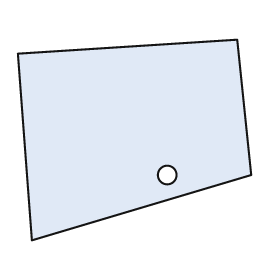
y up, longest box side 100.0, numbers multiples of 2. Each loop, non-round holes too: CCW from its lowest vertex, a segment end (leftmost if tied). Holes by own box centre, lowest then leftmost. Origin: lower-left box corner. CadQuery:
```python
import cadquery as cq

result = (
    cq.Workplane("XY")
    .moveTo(6.0, 0.0)
    .lineTo(100.0, 28.0)
    .lineTo(94.0, 86.0)
    .lineTo(0.0, 80.0)
    .close()
    .moveTo(64.0, 28.0)
    .circle(4.0)
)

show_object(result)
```